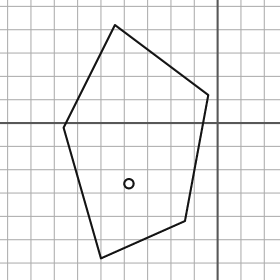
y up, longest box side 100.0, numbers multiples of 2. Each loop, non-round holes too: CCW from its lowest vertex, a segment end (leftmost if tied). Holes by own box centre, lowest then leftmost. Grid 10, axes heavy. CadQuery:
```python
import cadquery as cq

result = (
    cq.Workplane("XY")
    .moveTo(-50.0, -58.0)
    .lineTo(-14.0, -42.0)
    .lineTo(-4.0, 12.0)
    .lineTo(-44.0, 42.0)
    .lineTo(-66.0, -2.0)
    .close()
    .moveTo(-38.0, -26.0)
    .circle(2.0)
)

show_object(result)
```